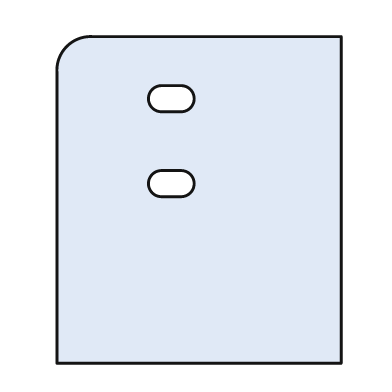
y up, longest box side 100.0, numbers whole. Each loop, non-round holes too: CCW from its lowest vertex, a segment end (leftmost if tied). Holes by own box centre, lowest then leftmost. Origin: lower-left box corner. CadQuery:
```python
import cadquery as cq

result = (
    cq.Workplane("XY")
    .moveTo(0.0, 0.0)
    .lineTo(87.0, 0.0)
    .lineTo(87.0, 100.0)
    .lineTo(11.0, 100.0)
    .threePointArc((3.0, 97.0), (0.0, 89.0))
    .close()
    .moveTo(32.0, 51.0)
    .lineTo(38.0, 51.0)
    .threePointArc((42.0, 55.0), (38.0, 59.0))
    .lineTo(32.0, 59.0)
    .threePointArc((28.0, 55.0), (32.0, 51.0))
    .close()
    .moveTo(32.0, 77.0)
    .lineTo(38.0, 77.0)
    .threePointArc((42.0, 81.0), (38.0, 85.0))
    .lineTo(32.0, 85.0)
    .threePointArc((28.0, 81.0), (32.0, 77.0))
    .close()
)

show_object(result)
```